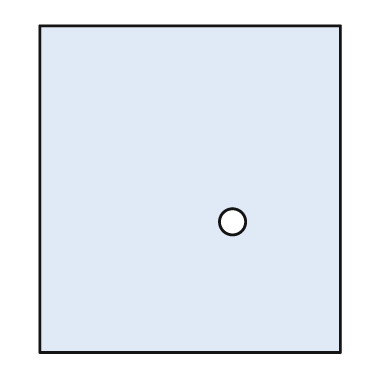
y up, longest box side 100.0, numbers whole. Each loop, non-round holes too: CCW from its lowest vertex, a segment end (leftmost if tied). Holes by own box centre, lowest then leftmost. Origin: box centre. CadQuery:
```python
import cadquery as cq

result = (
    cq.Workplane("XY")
    .moveTo(-46.0, -50.0)
    .lineTo(46.0, -50.0)
    .lineTo(46.0, 50.0)
    .lineTo(-46.0, 50.0)
    .close()
    .moveTo(13.0, -10.0)
    .circle(4.0)
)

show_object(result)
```